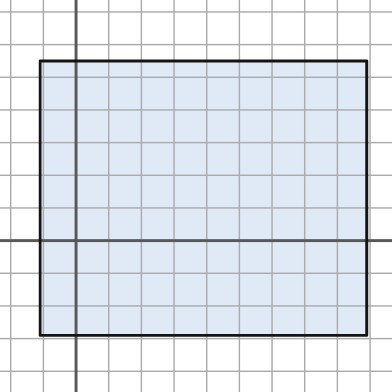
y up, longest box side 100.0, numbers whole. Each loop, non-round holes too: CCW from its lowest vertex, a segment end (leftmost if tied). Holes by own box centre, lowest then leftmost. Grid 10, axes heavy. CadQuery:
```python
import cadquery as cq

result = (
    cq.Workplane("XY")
    .moveTo(-11.0, -29.0)
    .lineTo(89.0, -29.0)
    .lineTo(89.0, 55.0)
    .lineTo(-11.0, 55.0)
    .close()
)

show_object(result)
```